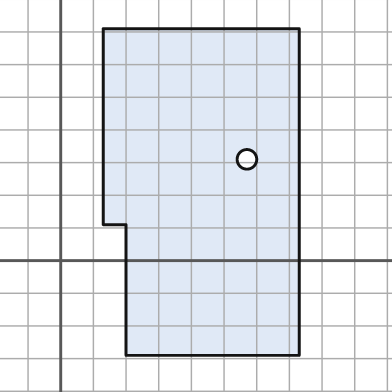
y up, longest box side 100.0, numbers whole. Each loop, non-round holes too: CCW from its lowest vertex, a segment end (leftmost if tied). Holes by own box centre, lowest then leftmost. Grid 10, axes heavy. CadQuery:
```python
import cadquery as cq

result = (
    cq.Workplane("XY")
    .moveTo(20.0, -29.0)
    .lineTo(73.0, -29.0)
    .lineTo(73.0, 71.0)
    .lineTo(13.0, 71.0)
    .lineTo(13.0, 11.0)
    .lineTo(20.0, 11.0)
    .close()
    .moveTo(57.0, 31.0)
    .circle(3.0)
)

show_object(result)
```